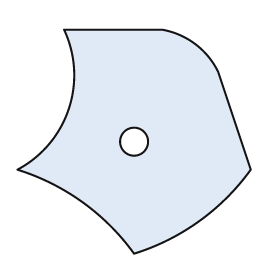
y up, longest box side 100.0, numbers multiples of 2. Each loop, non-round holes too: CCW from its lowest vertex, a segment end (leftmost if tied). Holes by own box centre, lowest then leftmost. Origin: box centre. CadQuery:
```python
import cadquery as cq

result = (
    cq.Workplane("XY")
    .moveTo(0.0, -48.0)
    .threePointArc((28.0, -34.0), (50.0, -12.0))
    .lineTo(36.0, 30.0)
    .threePointArc((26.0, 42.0), (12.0, 48.0))
    .lineTo(-30.0, 48.0)
    .threePointArc((-28.0, 14.0), (-50.0, -12.0))
    .threePointArc((-22.0, -26.0), (0.0, -48.0))
    .close()
    .moveTo(0.0, 0.0)
    .circle(6.0)
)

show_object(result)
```